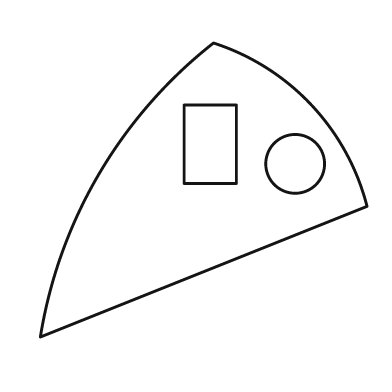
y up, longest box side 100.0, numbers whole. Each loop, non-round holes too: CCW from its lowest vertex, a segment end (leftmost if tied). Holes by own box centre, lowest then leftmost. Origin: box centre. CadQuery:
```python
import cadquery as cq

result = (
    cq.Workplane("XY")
    .moveTo(-50.0, -45.0)
    .lineTo(50.0, -5.0)
    .threePointArc((33.0, 26.0), (3.0, 45.0))
    .threePointArc((-32.0, 5.0), (-50.0, -45.0))
    .close()
    .moveTo(28.0, 8.0)
    .circle(9.0)
    .moveTo(-6.0, 2.0)
    .lineTo(10.0, 2.0)
    .lineTo(10.0, 26.0)
    .lineTo(-6.0, 26.0)
    .close()
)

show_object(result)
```